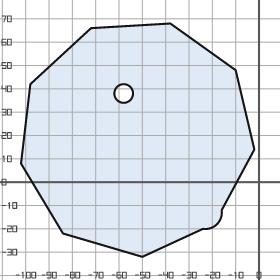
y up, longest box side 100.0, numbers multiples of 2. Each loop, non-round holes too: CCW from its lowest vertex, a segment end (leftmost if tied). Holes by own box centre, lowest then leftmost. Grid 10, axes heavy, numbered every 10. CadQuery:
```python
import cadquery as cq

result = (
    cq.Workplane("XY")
    .moveTo(-50.0, -32.0)
    .lineTo(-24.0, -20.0)
    .threePointArc((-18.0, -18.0), (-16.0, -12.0))
    .lineTo(-2.0, 14.0)
    .lineTo(-10.0, 48.0)
    .lineTo(-38.0, 68.0)
    .lineTo(-72.0, 66.0)
    .lineTo(-98.0, 42.0)
    .lineTo(-102.0, 8.0)
    .lineTo(-84.0, -22.0)
    .close()
    .moveTo(-58.0, 38.0)
    .circle(4.0)
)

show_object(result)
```